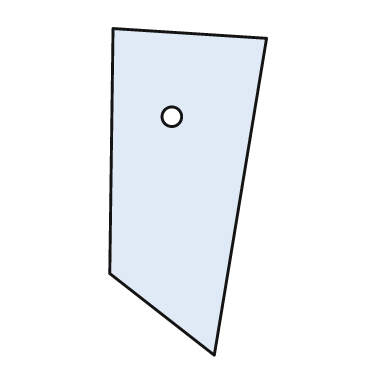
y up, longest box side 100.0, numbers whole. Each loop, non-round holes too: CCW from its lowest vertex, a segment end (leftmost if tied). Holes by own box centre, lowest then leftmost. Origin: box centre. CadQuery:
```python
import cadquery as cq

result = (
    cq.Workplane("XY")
    .moveTo(8.0, -50.0)
    .lineTo(24.0, 47.0)
    .lineTo(-23.0, 50.0)
    .lineTo(-24.0, -25.0)
    .close()
    .moveTo(-5.0, 23.0)
    .circle(3.0)
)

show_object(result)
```